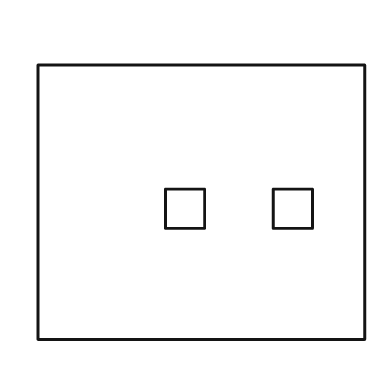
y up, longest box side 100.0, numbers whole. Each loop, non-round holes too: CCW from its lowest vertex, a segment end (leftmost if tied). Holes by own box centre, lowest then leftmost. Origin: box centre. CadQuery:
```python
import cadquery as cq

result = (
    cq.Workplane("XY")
    .moveTo(-50.0, -42.0)
    .lineTo(50.0, -42.0)
    .lineTo(50.0, 42.0)
    .lineTo(-50.0, 42.0)
    .close()
    .moveTo(-11.0, -8.0)
    .lineTo(1.0, -8.0)
    .lineTo(1.0, 4.0)
    .lineTo(-11.0, 4.0)
    .close()
    .moveTo(22.0, -8.0)
    .lineTo(34.0, -8.0)
    .lineTo(34.0, 4.0)
    .lineTo(22.0, 4.0)
    .close()
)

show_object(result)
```